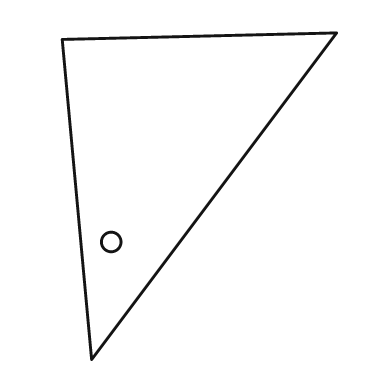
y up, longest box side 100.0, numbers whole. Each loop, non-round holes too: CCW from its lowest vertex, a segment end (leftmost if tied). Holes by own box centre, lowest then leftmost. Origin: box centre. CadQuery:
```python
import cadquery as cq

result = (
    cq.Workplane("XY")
    .moveTo(-33.0, -50.0)
    .lineTo(42.0, 50.0)
    .lineTo(-42.0, 48.0)
    .close()
    .moveTo(-27.0, -14.0)
    .circle(3.0)
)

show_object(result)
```